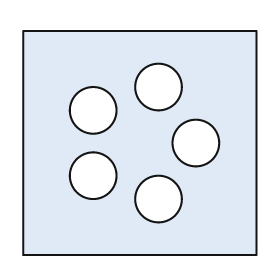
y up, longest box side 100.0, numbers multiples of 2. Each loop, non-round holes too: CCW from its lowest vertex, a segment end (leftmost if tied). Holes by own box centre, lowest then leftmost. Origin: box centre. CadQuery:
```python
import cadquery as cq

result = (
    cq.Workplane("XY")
    .moveTo(-50.0, -48.0)
    .lineTo(50.0, -48.0)
    .lineTo(50.0, 48.0)
    .lineTo(-50.0, 48.0)
    .close()
    .moveTo(8.0, -24.0)
    .circle(10.0)
    .moveTo(-20.0, -14.0)
    .circle(10.0)
    .moveTo(24.0, 0.0)
    .circle(10.0)
    .moveTo(-20.0, 14.0)
    .circle(10.0)
    .moveTo(8.0, 24.0)
    .circle(10.0)
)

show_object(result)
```